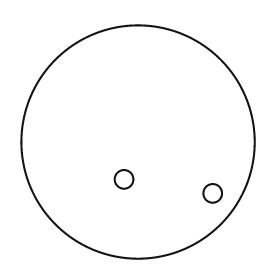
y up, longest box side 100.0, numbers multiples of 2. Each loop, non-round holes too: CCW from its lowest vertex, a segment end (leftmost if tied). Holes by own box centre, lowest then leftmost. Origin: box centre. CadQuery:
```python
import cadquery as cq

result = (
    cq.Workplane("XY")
    .moveTo(0.0, 0.0)
    .circle(50.0)
    .moveTo(32.0, -22.0)
    .circle(4.0)
    .moveTo(-6.0, -16.0)
    .circle(4.0)
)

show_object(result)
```